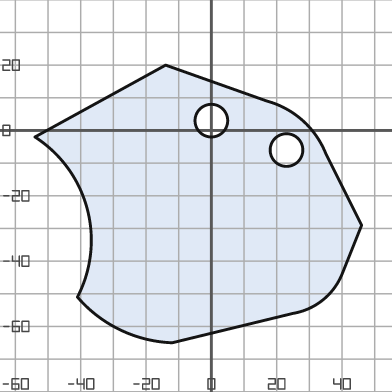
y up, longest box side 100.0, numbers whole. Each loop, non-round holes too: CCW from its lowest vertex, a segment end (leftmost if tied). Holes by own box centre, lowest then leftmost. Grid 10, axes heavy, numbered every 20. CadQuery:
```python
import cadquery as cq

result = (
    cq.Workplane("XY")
    .moveTo(-12.0, -65.0)
    .lineTo(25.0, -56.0)
    .threePointArc((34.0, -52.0), (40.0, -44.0))
    .lineTo(46.0, -29.0)
    .lineTo(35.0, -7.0)
    .threePointArc((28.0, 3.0), (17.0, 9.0))
    .lineTo(-14.0, 20.0)
    .lineTo(-54.0, -2.0)
    .threePointArc((-38.0, -24.0), (-41.0, -51.0))
    .threePointArc((-28.0, -61.0), (-12.0, -65.0))
    .close()
    .moveTo(23.0, -6.0)
    .circle(5.0)
    .moveTo(0.0, 3.0)
    .circle(5.0)
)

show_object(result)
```